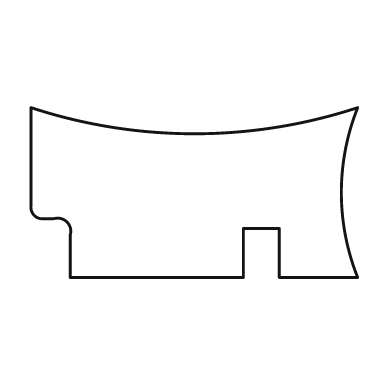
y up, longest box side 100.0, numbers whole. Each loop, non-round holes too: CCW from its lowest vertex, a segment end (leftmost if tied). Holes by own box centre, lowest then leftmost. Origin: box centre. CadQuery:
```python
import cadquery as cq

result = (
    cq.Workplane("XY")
    .moveTo(-38.0, -26.0)
    .lineTo(15.0, -26.0)
    .lineTo(15.0, -11.0)
    .lineTo(26.0, -11.0)
    .lineTo(26.0, -26.0)
    .lineTo(50.0, -26.0)
    .threePointArc((45.0, 0.0), (50.0, 26.0))
    .threePointArc((0.0, 18.0), (-50.0, 26.0))
    .lineTo(-50.0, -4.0)
    .threePointArc((-49.0, -7.0), (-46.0, -8.0))
    .lineTo(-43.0, -8.0)
    .threePointArc((-39.0, -9.0), (-38.0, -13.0))
    .close()
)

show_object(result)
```